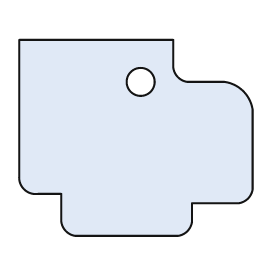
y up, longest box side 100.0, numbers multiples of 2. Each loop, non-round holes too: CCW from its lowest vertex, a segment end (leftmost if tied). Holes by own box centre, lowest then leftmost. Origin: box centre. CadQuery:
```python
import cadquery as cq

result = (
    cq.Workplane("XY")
    .moveTo(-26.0, -42.0)
    .lineTo(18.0, -42.0)
    .threePointArc((22.0, -40.0), (24.0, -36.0))
    .lineTo(24.0, -28.0)
    .lineTo(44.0, -28.0)
    .threePointArc((48.0, -26.0), (50.0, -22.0))
    .lineTo(50.0, 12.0)
    .threePointArc((46.0, 20.0), (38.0, 24.0))
    .lineTo(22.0, 24.0)
    .threePointArc((18.0, 26.0), (16.0, 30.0))
    .lineTo(16.0, 42.0)
    .lineTo(-50.0, 42.0)
    .lineTo(-50.0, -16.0)
    .threePointArc((-48.0, -22.0), (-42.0, -24.0))
    .lineTo(-32.0, -24.0)
    .lineTo(-32.0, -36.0)
    .threePointArc((-30.0, -40.0), (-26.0, -42.0))
    .close()
    .moveTo(2.0, 24.0)
    .circle(6.0)
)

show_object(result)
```